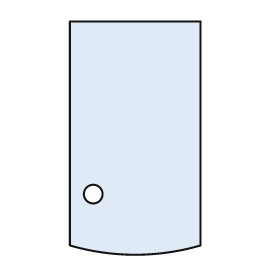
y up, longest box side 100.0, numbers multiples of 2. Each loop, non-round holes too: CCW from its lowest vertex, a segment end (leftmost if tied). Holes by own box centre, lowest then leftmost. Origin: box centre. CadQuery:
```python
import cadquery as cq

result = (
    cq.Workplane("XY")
    .moveTo(-28.0, -46.0)
    .threePointArc((0.0, -50.0), (28.0, -46.0))
    .lineTo(28.0, 50.0)
    .lineTo(-28.0, 50.0)
    .close()
    .moveTo(-18.0, -24.0)
    .circle(4.0)
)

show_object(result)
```